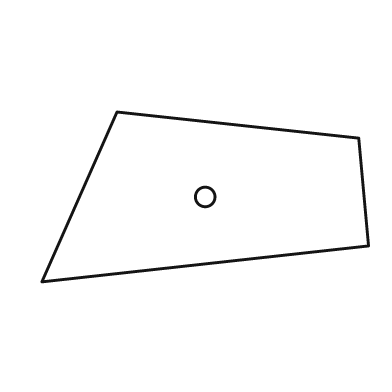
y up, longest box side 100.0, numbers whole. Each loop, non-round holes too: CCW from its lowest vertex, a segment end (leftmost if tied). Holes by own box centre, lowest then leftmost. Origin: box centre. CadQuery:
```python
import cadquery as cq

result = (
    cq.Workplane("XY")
    .moveTo(-50.0, -26.0)
    .lineTo(50.0, -15.0)
    .lineTo(47.0, 18.0)
    .lineTo(-27.0, 26.0)
    .close()
    .moveTo(0.0, 0.0)
    .circle(3.0)
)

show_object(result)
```